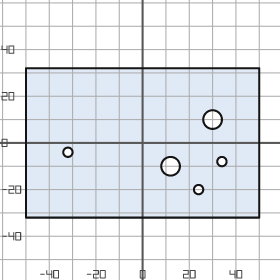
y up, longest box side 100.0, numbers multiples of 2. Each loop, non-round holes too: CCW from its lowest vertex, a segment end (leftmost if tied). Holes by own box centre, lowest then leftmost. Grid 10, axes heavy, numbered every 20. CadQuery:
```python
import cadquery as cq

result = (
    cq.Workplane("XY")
    .moveTo(-50.0, -32.0)
    .lineTo(50.0, -32.0)
    .lineTo(50.0, 32.0)
    .lineTo(-50.0, 32.0)
    .close()
    .moveTo(24.0, -20.0)
    .circle(2.0)
    .moveTo(12.0, -10.0)
    .circle(4.0)
    .moveTo(34.0, -8.0)
    .circle(2.0)
    .moveTo(-32.0, -4.0)
    .circle(2.0)
    .moveTo(30.0, 10.0)
    .circle(4.0)
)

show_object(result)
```